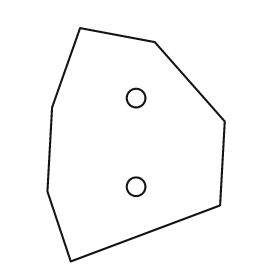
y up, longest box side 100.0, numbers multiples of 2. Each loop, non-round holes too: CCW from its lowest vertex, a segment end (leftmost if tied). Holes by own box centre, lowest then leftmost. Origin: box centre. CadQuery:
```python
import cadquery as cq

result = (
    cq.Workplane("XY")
    .moveTo(-28.0, -50.0)
    .lineTo(36.0, -26.0)
    .lineTo(38.0, 10.0)
    .lineTo(8.0, 44.0)
    .lineTo(-24.0, 50.0)
    .lineTo(-36.0, 16.0)
    .lineTo(-38.0, -20.0)
    .close()
    .moveTo(0.0, -18.0)
    .circle(4.0)
    .moveTo(0.0, 20.0)
    .circle(4.0)
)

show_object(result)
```